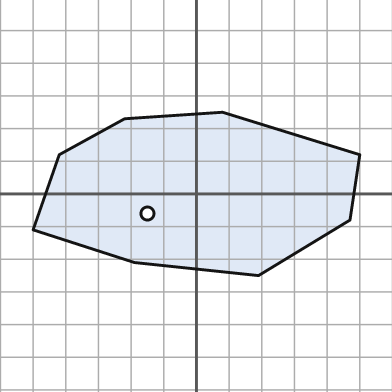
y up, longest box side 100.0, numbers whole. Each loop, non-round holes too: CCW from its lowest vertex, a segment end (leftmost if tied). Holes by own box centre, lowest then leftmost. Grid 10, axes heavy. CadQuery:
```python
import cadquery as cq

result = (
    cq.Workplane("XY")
    .moveTo(19.0, -25.0)
    .lineTo(47.0, -8.0)
    .lineTo(50.0, 12.0)
    .lineTo(8.0, 25.0)
    .lineTo(-22.0, 23.0)
    .lineTo(-42.0, 12.0)
    .lineTo(-50.0, -11.0)
    .lineTo(-19.0, -21.0)
    .close()
    .moveTo(-15.0, -6.0)
    .circle(2.0)
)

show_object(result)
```